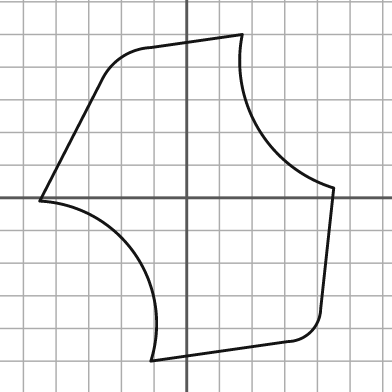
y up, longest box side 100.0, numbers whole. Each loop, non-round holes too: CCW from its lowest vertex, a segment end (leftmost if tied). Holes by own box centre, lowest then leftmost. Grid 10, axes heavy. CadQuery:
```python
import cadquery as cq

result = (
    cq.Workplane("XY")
    .moveTo(-11.0, -50.0)
    .lineTo(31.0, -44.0)
    .threePointArc((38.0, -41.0), (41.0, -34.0))
    .lineTo(45.0, 3.0)
    .threePointArc((22.0, 21.0), (17.0, 50.0))
    .lineTo(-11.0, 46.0)
    .threePointArc((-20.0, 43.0), (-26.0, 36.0))
    .lineTo(-45.0, -1.0)
    .threePointArc((-16.0, -17.0), (-11.0, -50.0))
    .close()
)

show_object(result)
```